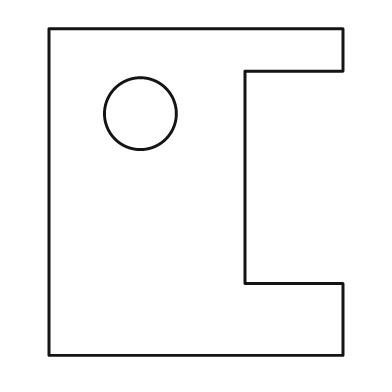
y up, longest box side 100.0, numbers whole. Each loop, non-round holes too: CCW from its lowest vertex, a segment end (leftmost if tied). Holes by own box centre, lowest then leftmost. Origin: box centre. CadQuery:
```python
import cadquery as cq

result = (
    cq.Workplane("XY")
    .moveTo(-45.0, -50.0)
    .lineTo(45.0, -50.0)
    .lineTo(45.0, -28.0)
    .lineTo(15.0, -28.0)
    .lineTo(15.0, 37.0)
    .lineTo(45.0, 37.0)
    .lineTo(45.0, 50.0)
    .lineTo(-45.0, 50.0)
    .close()
    .moveTo(-17.0, 24.0)
    .circle(11.0)
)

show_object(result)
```